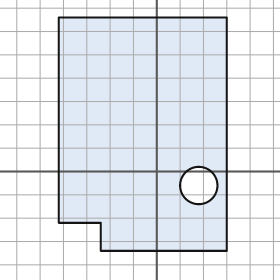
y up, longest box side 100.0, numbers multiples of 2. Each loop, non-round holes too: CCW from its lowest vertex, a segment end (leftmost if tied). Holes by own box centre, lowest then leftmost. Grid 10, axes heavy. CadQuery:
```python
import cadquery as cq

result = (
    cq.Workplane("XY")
    .moveTo(-24.0, -34.0)
    .lineTo(30.0, -34.0)
    .lineTo(30.0, 66.0)
    .lineTo(-42.0, 66.0)
    .lineTo(-42.0, -22.0)
    .lineTo(-24.0, -22.0)
    .close()
    .moveTo(18.0, -6.0)
    .circle(8.0)
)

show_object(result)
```